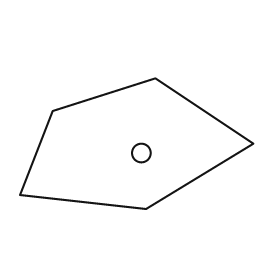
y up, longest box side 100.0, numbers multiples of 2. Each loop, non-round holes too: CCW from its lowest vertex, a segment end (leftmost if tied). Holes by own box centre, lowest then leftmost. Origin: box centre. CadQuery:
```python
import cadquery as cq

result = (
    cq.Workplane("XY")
    .moveTo(4.0, -28.0)
    .lineTo(50.0, 0.0)
    .lineTo(8.0, 28.0)
    .lineTo(-36.0, 14.0)
    .lineTo(-50.0, -22.0)
    .close()
    .moveTo(2.0, -4.0)
    .circle(4.0)
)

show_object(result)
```